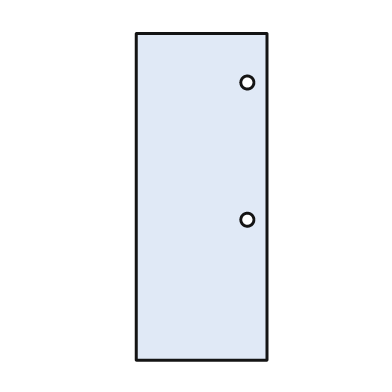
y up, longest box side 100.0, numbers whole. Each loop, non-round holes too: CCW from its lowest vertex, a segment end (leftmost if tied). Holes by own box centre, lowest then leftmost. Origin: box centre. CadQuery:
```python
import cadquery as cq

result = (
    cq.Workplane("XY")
    .moveTo(-20.0, -50.0)
    .lineTo(20.0, -50.0)
    .lineTo(20.0, 50.0)
    .lineTo(-20.0, 50.0)
    .close()
    .moveTo(14.0, -7.0)
    .circle(2.0)
    .moveTo(14.0, 35.0)
    .circle(2.0)
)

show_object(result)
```